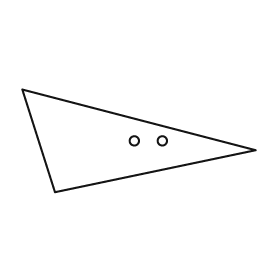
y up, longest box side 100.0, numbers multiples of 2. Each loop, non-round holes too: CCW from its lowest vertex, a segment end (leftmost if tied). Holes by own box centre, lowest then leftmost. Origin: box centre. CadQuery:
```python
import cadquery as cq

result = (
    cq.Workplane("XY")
    .moveTo(-36.0, -22.0)
    .lineTo(50.0, -4.0)
    .lineTo(-50.0, 22.0)
    .close()
    .moveTo(-2.0, 0.0)
    .circle(2.0)
    .moveTo(10.0, 0.0)
    .circle(2.0)
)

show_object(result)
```